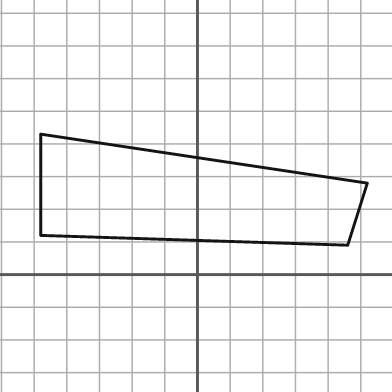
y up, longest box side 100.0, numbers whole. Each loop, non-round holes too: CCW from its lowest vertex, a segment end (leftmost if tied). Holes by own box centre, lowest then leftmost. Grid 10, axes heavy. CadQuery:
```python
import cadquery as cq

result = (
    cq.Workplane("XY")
    .moveTo(46.0, 9.0)
    .lineTo(52.0, 28.0)
    .lineTo(-48.0, 43.0)
    .lineTo(-48.0, 12.0)
    .close()
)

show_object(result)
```